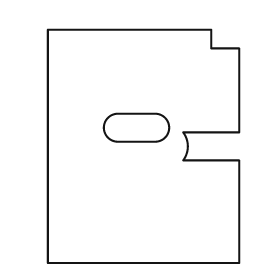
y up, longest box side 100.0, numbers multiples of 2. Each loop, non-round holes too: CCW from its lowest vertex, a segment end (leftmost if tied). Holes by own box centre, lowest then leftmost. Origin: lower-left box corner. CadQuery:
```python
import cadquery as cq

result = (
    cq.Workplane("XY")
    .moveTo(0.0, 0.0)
    .lineTo(82.0, 0.0)
    .lineTo(82.0, 44.0)
    .lineTo(58.0, 44.0)
    .threePointArc((60.0, 50.0), (58.0, 56.0))
    .lineTo(82.0, 56.0)
    .lineTo(82.0, 92.0)
    .lineTo(70.0, 92.0)
    .lineTo(70.0, 100.0)
    .lineTo(0.0, 100.0)
    .close()
    .moveTo(30.0, 52.0)
    .lineTo(46.0, 52.0)
    .threePointArc((52.0, 58.0), (46.0, 64.0))
    .lineTo(30.0, 64.0)
    .threePointArc((24.0, 58.0), (30.0, 52.0))
    .close()
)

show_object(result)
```